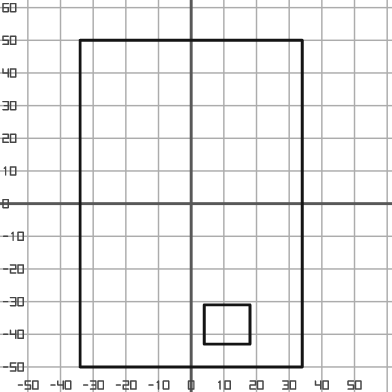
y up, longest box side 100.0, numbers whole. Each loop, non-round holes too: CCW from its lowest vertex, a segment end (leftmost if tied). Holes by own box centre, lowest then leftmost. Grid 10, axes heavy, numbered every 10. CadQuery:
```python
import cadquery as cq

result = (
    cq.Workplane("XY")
    .moveTo(-34.0, -50.0)
    .lineTo(34.0, -50.0)
    .lineTo(34.0, 50.0)
    .lineTo(-34.0, 50.0)
    .close()
    .moveTo(4.0, -43.0)
    .lineTo(18.0, -43.0)
    .lineTo(18.0, -31.0)
    .lineTo(4.0, -31.0)
    .close()
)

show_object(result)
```